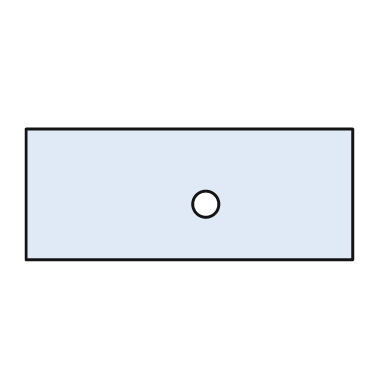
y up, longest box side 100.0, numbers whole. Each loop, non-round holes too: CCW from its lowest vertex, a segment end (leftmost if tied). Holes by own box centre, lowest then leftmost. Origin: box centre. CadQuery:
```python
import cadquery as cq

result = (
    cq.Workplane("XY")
    .moveTo(-50.0, -20.0)
    .lineTo(50.0, -20.0)
    .lineTo(50.0, 20.0)
    .lineTo(-50.0, 20.0)
    .close()
    .moveTo(5.0, -3.0)
    .circle(4.0)
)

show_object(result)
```